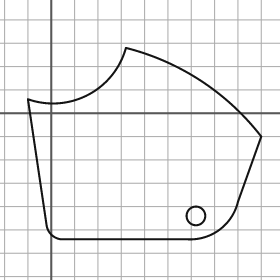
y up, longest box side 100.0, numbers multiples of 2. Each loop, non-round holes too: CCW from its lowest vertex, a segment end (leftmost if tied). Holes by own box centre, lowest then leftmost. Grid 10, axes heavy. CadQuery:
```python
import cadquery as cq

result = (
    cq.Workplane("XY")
    .moveTo(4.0, -54.0)
    .lineTo(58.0, -54.0)
    .threePointArc((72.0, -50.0), (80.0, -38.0))
    .lineTo(90.0, -10.0)
    .threePointArc((64.0, 14.0), (32.0, 28.0))
    .threePointArc((16.0, 8.0), (-10.0, 6.0))
    .lineTo(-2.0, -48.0)
    .threePointArc((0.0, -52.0), (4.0, -54.0))
    .close()
    .moveTo(62.0, -44.0)
    .circle(4.0)
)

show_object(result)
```